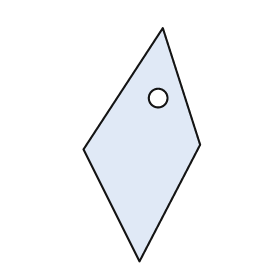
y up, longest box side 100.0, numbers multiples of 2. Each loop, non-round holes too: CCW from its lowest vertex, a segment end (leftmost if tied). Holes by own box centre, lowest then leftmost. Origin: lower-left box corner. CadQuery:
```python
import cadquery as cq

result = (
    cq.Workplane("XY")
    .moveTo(24.0, 0.0)
    .lineTo(50.0, 50.0)
    .lineTo(34.0, 100.0)
    .lineTo(0.0, 48.0)
    .close()
    .moveTo(32.0, 70.0)
    .circle(4.0)
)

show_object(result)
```